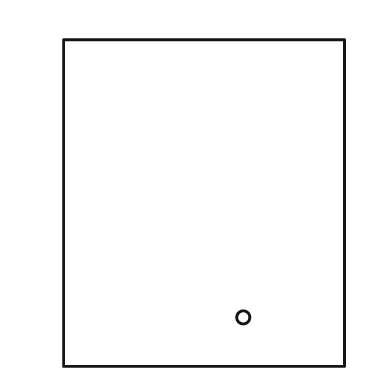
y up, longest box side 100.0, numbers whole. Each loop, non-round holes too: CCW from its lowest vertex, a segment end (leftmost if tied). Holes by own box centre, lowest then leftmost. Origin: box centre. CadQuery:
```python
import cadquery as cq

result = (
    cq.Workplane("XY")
    .moveTo(-43.0, -50.0)
    .lineTo(43.0, -50.0)
    .lineTo(43.0, 50.0)
    .lineTo(-43.0, 50.0)
    .close()
    .moveTo(12.0, -35.0)
    .circle(2.0)
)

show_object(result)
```